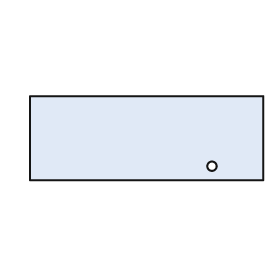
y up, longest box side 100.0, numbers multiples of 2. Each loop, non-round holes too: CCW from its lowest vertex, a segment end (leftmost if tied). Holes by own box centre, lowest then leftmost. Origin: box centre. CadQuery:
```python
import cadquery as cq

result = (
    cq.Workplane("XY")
    .moveTo(-50.0, -18.0)
    .lineTo(50.0, -18.0)
    .lineTo(50.0, 18.0)
    .lineTo(-50.0, 18.0)
    .close()
    .moveTo(28.0, -12.0)
    .circle(2.0)
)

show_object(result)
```